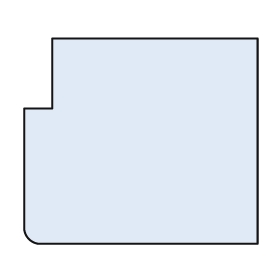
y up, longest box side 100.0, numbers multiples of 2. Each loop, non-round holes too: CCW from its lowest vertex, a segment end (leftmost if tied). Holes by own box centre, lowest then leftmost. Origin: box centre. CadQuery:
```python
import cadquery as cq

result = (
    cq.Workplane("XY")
    .moveTo(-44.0, -44.0)
    .lineTo(50.0, -44.0)
    .lineTo(50.0, 44.0)
    .lineTo(-38.0, 44.0)
    .lineTo(-38.0, 14.0)
    .lineTo(-50.0, 14.0)
    .lineTo(-50.0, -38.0)
    .threePointArc((-48.0, -42.0), (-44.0, -44.0))
    .close()
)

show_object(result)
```